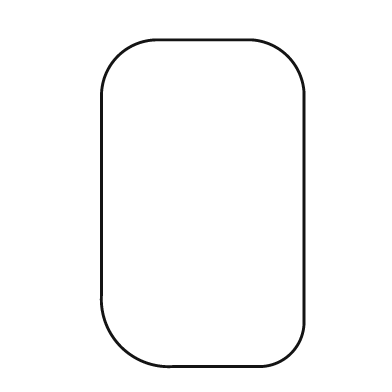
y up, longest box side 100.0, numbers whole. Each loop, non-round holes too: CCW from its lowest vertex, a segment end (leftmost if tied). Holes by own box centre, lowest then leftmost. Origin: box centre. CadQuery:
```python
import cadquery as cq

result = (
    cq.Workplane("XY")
    .moveTo(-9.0, -50.0)
    .lineTo(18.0, -50.0)
    .threePointArc((27.0, -46.0), (31.0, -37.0))
    .lineTo(31.0, 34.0)
    .threePointArc((26.0, 45.0), (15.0, 50.0))
    .lineTo(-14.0, 50.0)
    .threePointArc((-26.0, 45.0), (-31.0, 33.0))
    .lineTo(-31.0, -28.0)
    .threePointArc((-25.0, -44.0), (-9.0, -50.0))
    .close()
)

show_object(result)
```